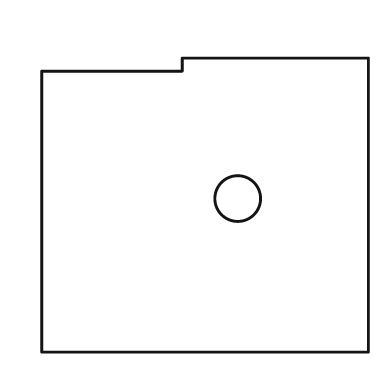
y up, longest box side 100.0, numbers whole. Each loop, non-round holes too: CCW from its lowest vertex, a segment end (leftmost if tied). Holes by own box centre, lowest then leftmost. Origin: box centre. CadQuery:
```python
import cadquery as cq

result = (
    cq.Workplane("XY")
    .moveTo(-50.0, -45.0)
    .lineTo(50.0, -45.0)
    .lineTo(50.0, 45.0)
    .lineTo(-7.0, 45.0)
    .lineTo(-7.0, 41.0)
    .lineTo(-50.0, 41.0)
    .close()
    .moveTo(10.0, 2.0)
    .circle(7.0)
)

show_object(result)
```